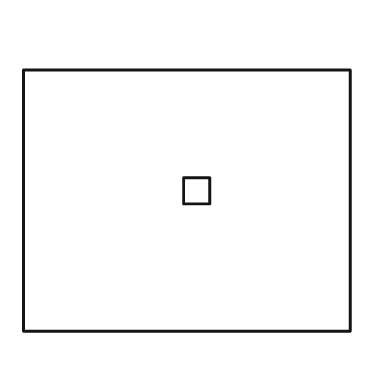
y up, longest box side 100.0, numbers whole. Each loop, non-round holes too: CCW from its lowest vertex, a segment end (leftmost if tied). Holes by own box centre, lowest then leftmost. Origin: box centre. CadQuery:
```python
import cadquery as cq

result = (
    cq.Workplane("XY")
    .moveTo(-50.0, -40.0)
    .lineTo(50.0, -40.0)
    .lineTo(50.0, 40.0)
    .lineTo(-50.0, 40.0)
    .close()
    .moveTo(-1.0, -1.0)
    .lineTo(7.0, -1.0)
    .lineTo(7.0, 7.0)
    .lineTo(-1.0, 7.0)
    .close()
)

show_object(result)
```